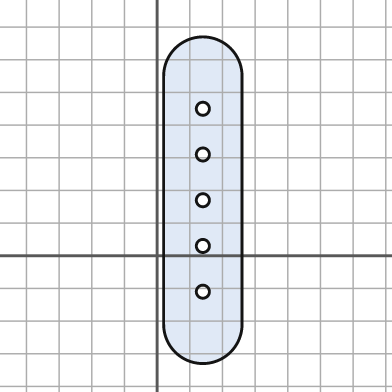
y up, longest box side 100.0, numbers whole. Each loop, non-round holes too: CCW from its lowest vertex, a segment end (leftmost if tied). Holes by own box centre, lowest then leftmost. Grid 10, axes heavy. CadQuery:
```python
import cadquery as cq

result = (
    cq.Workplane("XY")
    .moveTo(2.0, -21.0)
    .threePointArc((14.0, -33.0), (26.0, -21.0))
    .lineTo(26.0, 55.0)
    .threePointArc((14.0, 67.0), (2.0, 55.0))
    .close()
    .moveTo(14.0, -11.0)
    .circle(2.0)
    .moveTo(14.0, 3.0)
    .circle(2.0)
    .moveTo(14.0, 17.0)
    .circle(2.0)
    .moveTo(14.0, 31.0)
    .circle(2.0)
    .moveTo(14.0, 45.0)
    .circle(2.0)
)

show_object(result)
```